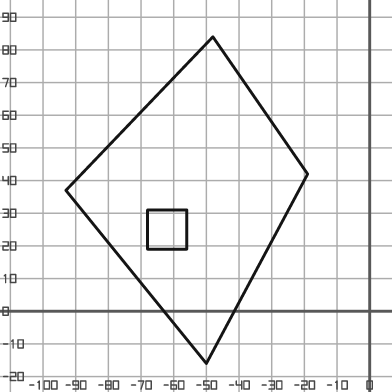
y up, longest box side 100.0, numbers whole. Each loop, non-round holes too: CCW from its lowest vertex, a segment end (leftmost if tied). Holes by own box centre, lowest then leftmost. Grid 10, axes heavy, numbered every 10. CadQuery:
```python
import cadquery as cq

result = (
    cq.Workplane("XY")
    .moveTo(-50.0, -16.0)
    .lineTo(-19.0, 42.0)
    .lineTo(-48.0, 84.0)
    .lineTo(-93.0, 37.0)
    .close()
    .moveTo(-68.0, 19.0)
    .lineTo(-56.0, 19.0)
    .lineTo(-56.0, 31.0)
    .lineTo(-68.0, 31.0)
    .close()
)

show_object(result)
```